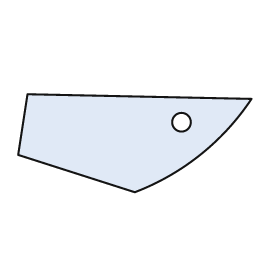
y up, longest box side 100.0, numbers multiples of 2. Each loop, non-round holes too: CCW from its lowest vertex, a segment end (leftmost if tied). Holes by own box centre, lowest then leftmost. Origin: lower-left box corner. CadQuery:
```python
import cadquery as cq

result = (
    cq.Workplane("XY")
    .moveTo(50.0, 0.0)
    .threePointArc((78.0, 16.0), (100.0, 40.0))
    .lineTo(4.0, 42.0)
    .lineTo(0.0, 16.0)
    .close()
    .moveTo(70.0, 30.0)
    .circle(4.0)
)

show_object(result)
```